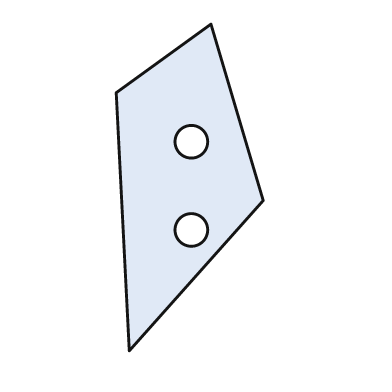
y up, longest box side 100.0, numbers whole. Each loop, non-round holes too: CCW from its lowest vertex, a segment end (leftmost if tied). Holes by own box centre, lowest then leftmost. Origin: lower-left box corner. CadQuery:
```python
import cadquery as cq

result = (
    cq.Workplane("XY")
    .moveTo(4.0, 0.0)
    .lineTo(45.0, 46.0)
    .lineTo(29.0, 100.0)
    .lineTo(0.0, 79.0)
    .close()
    .moveTo(23.0, 37.0)
    .circle(5.0)
    .moveTo(23.0, 64.0)
    .circle(5.0)
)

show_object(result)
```